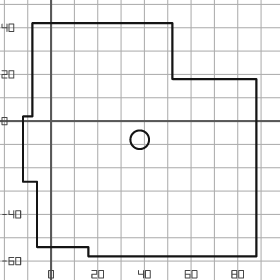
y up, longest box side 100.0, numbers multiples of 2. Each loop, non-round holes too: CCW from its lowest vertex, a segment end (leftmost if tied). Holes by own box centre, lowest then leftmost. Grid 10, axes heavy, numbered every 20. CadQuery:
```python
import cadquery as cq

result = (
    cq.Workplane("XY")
    .moveTo(16.0, -58.0)
    .lineTo(88.0, -58.0)
    .lineTo(88.0, 18.0)
    .lineTo(52.0, 18.0)
    .lineTo(52.0, 42.0)
    .lineTo(-8.0, 42.0)
    .lineTo(-8.0, 2.0)
    .lineTo(-12.0, 2.0)
    .lineTo(-12.0, -26.0)
    .lineTo(-6.0, -26.0)
    .lineTo(-6.0, -54.0)
    .lineTo(16.0, -54.0)
    .close()
    .moveTo(38.0, -8.0)
    .circle(4.0)
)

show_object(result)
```